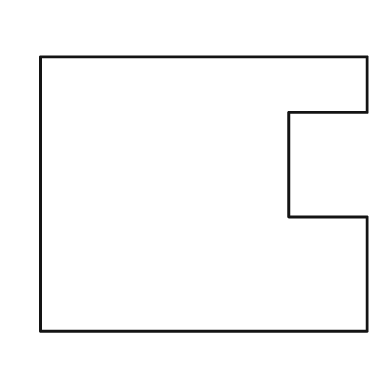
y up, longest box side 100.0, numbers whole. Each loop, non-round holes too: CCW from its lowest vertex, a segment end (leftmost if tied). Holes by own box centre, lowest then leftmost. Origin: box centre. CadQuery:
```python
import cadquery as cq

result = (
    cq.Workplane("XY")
    .moveTo(-50.0, -42.0)
    .lineTo(50.0, -42.0)
    .lineTo(50.0, -7.0)
    .lineTo(26.0, -7.0)
    .lineTo(26.0, 25.0)
    .lineTo(50.0, 25.0)
    .lineTo(50.0, 42.0)
    .lineTo(-50.0, 42.0)
    .close()
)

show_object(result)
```